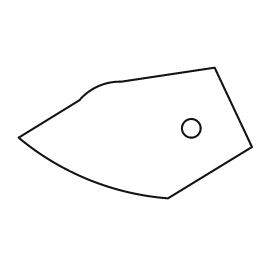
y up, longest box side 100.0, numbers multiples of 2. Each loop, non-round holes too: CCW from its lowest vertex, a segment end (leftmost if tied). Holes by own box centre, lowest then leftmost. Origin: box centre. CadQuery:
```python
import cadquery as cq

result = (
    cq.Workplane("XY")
    .moveTo(14.0, -28.0)
    .lineTo(50.0, -6.0)
    .lineTo(34.0, 28.0)
    .lineTo(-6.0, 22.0)
    .threePointArc((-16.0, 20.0), (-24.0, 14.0))
    .lineTo(-50.0, -2.0)
    .threePointArc((-20.0, -20.0), (14.0, -28.0))
    .close()
    .moveTo(24.0, 2.0)
    .circle(4.0)
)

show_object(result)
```